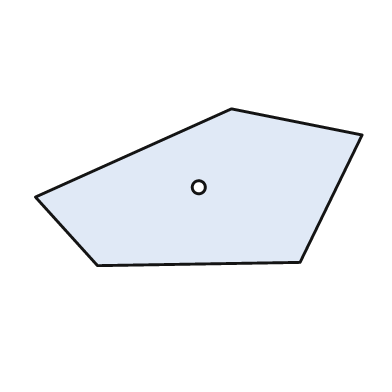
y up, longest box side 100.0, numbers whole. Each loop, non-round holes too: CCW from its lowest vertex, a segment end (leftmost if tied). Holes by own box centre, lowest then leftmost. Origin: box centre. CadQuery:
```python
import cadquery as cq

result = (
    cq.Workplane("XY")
    .moveTo(-31.0, -24.0)
    .lineTo(31.0, -23.0)
    .lineTo(50.0, 16.0)
    .lineTo(10.0, 24.0)
    .lineTo(-50.0, -3.0)
    .close()
    .moveTo(0.0, 0.0)
    .circle(2.0)
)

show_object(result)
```